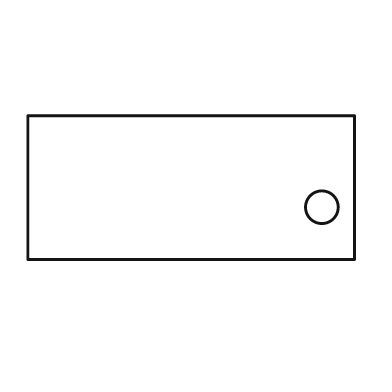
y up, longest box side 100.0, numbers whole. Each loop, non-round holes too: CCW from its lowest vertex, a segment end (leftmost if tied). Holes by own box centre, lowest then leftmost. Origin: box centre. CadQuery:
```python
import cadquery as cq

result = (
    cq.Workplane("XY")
    .moveTo(-50.0, -22.0)
    .lineTo(50.0, -22.0)
    .lineTo(50.0, 22.0)
    .lineTo(-50.0, 22.0)
    .close()
    .moveTo(40.0, -6.0)
    .circle(5.0)
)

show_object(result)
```